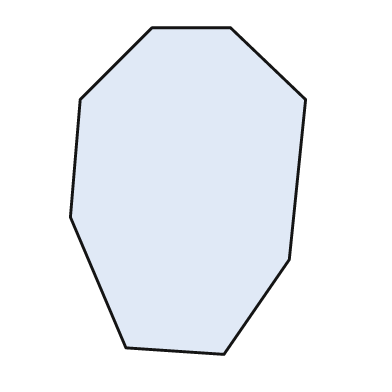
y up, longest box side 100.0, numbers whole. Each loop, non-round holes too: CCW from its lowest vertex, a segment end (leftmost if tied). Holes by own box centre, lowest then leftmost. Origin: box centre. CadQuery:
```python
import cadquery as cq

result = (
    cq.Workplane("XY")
    .moveTo(11.0, -50.0)
    .lineTo(31.0, -21.0)
    .lineTo(36.0, 28.0)
    .lineTo(13.0, 50.0)
    .lineTo(-11.0, 50.0)
    .lineTo(-33.0, 28.0)
    .lineTo(-36.0, -8.0)
    .lineTo(-19.0, -48.0)
    .close()
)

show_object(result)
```